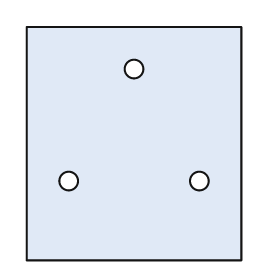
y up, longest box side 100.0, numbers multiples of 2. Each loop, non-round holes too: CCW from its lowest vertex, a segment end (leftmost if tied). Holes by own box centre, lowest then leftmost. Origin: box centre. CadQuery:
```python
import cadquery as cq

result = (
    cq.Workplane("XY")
    .moveTo(-46.0, -50.0)
    .lineTo(46.0, -50.0)
    .lineTo(46.0, 50.0)
    .lineTo(-46.0, 50.0)
    .close()
    .moveTo(-28.0, -16.0)
    .circle(4.0)
    .moveTo(28.0, -16.0)
    .circle(4.0)
    .moveTo(0.0, 32.0)
    .circle(4.0)
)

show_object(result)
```